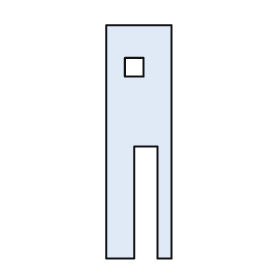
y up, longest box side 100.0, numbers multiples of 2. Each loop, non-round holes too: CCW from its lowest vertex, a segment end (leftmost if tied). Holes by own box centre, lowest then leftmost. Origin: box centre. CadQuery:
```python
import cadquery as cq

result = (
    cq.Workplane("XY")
    .moveTo(-14.0, -50.0)
    .lineTo(-2.0, -50.0)
    .lineTo(-2.0, -2.0)
    .lineTo(8.0, -2.0)
    .lineTo(8.0, -50.0)
    .lineTo(14.0, -50.0)
    .lineTo(14.0, 50.0)
    .lineTo(-14.0, 50.0)
    .close()
    .moveTo(-6.0, 28.0)
    .lineTo(2.0, 28.0)
    .lineTo(2.0, 36.0)
    .lineTo(-6.0, 36.0)
    .close()
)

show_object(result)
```